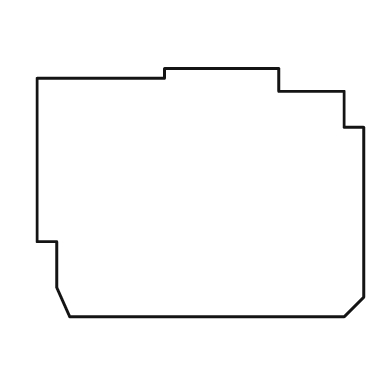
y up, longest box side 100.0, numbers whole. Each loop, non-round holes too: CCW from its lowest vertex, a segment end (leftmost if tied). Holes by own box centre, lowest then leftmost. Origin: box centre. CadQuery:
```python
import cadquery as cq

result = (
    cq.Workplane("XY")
    .moveTo(-40.0, -38.0)
    .lineTo(44.0, -38.0)
    .lineTo(50.0, -32.0)
    .lineTo(50.0, 20.0)
    .lineTo(44.0, 20.0)
    .lineTo(44.0, 31.0)
    .lineTo(24.0, 31.0)
    .lineTo(24.0, 38.0)
    .lineTo(-11.0, 38.0)
    .lineTo(-11.0, 35.0)
    .lineTo(-50.0, 35.0)
    .lineTo(-50.0, -15.0)
    .lineTo(-44.0, -15.0)
    .lineTo(-44.0, -29.0)
    .close()
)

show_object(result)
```